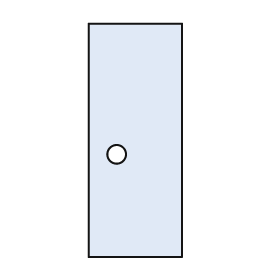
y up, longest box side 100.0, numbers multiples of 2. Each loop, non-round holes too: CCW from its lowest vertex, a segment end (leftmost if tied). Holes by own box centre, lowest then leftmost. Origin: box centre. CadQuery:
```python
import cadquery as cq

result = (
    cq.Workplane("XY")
    .moveTo(-20.0, -50.0)
    .lineTo(20.0, -50.0)
    .lineTo(20.0, 50.0)
    .lineTo(-20.0, 50.0)
    .close()
    .moveTo(-8.0, -6.0)
    .circle(4.0)
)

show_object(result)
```